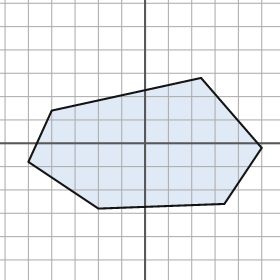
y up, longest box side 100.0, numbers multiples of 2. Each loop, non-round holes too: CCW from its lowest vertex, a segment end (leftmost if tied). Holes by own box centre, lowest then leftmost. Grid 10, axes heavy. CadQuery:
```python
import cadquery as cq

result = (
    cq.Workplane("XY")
    .moveTo(-20.0, -28.0)
    .lineTo(34.0, -26.0)
    .lineTo(50.0, -2.0)
    .lineTo(24.0, 28.0)
    .lineTo(-40.0, 14.0)
    .lineTo(-50.0, -8.0)
    .close()
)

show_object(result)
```